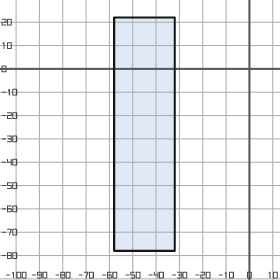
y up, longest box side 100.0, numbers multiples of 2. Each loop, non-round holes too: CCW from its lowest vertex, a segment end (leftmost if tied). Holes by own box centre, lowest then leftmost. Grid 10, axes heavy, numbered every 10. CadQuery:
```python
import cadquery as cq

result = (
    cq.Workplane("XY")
    .moveTo(-58.0, -78.0)
    .lineTo(-32.0, -78.0)
    .lineTo(-32.0, 22.0)
    .lineTo(-58.0, 22.0)
    .close()
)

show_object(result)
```